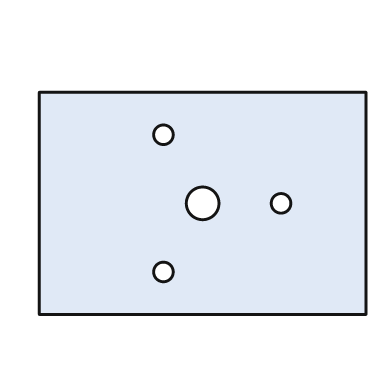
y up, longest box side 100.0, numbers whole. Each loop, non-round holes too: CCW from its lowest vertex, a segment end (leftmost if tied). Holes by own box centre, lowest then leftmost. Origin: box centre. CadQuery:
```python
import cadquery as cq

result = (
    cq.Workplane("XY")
    .moveTo(-50.0, -34.0)
    .lineTo(50.0, -34.0)
    .lineTo(50.0, 34.0)
    .lineTo(-50.0, 34.0)
    .close()
    .moveTo(-12.0, -21.0)
    .circle(3.0)
    .moveTo(0.0, 0.0)
    .circle(5.0)
    .moveTo(24.0, 0.0)
    .circle(3.0)
    .moveTo(-12.0, 21.0)
    .circle(3.0)
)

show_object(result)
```